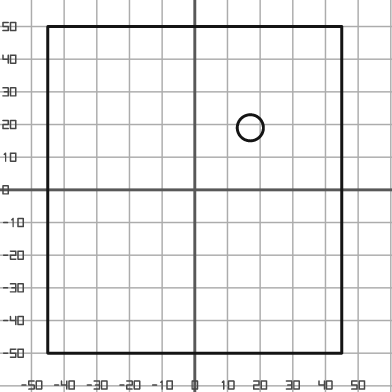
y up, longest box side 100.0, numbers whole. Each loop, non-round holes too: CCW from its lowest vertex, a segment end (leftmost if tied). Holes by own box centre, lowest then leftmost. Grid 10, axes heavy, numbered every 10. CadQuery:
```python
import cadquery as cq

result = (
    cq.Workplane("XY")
    .moveTo(-45.0, -50.0)
    .lineTo(45.0, -50.0)
    .lineTo(45.0, 50.0)
    .lineTo(-45.0, 50.0)
    .close()
    .moveTo(17.0, 19.0)
    .circle(4.0)
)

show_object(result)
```